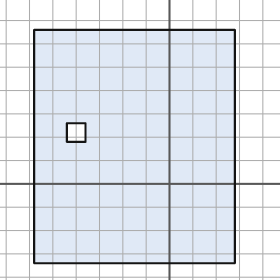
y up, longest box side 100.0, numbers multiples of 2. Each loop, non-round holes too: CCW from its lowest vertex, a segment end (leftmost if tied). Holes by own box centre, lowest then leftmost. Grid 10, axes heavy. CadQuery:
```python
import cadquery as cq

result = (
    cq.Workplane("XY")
    .moveTo(-58.0, -34.0)
    .lineTo(28.0, -34.0)
    .lineTo(28.0, 66.0)
    .lineTo(-58.0, 66.0)
    .close()
    .moveTo(-44.0, 18.0)
    .lineTo(-36.0, 18.0)
    .lineTo(-36.0, 26.0)
    .lineTo(-44.0, 26.0)
    .close()
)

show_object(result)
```